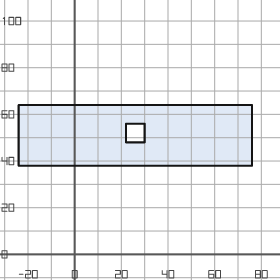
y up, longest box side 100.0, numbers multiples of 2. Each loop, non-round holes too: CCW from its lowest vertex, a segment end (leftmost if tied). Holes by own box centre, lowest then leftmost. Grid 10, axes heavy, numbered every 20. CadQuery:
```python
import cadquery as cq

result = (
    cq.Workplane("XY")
    .moveTo(-24.0, 38.0)
    .lineTo(76.0, 38.0)
    .lineTo(76.0, 64.0)
    .lineTo(-24.0, 64.0)
    .close()
    .moveTo(22.0, 48.0)
    .lineTo(30.0, 48.0)
    .lineTo(30.0, 56.0)
    .lineTo(22.0, 56.0)
    .close()
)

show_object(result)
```